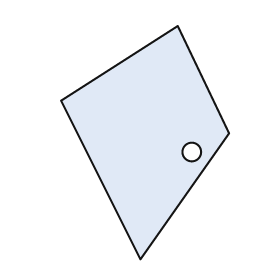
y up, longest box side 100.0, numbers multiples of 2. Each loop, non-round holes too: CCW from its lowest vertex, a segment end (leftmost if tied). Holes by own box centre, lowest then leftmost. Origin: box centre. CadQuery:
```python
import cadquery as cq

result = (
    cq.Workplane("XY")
    .moveTo(-2.0, -50.0)
    .lineTo(36.0, 4.0)
    .lineTo(14.0, 50.0)
    .lineTo(-36.0, 18.0)
    .close()
    .moveTo(20.0, -4.0)
    .circle(4.0)
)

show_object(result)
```